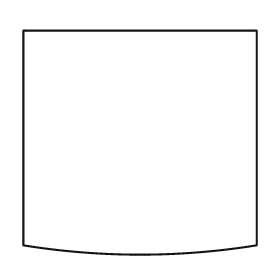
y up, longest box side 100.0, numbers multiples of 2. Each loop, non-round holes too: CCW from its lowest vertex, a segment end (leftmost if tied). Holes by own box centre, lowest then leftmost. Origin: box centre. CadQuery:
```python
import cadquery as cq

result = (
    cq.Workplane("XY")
    .moveTo(-50.0, -44.0)
    .threePointArc((0.0, -48.0), (50.0, -44.0))
    .lineTo(50.0, 48.0)
    .lineTo(-50.0, 48.0)
    .close()
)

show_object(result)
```